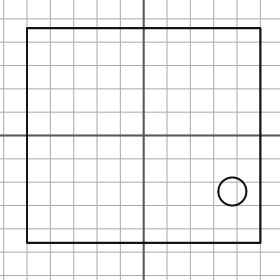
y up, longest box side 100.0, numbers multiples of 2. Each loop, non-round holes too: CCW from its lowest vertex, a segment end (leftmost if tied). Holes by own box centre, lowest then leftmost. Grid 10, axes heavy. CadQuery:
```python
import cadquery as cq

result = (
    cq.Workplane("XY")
    .moveTo(-50.0, -46.0)
    .lineTo(50.0, -46.0)
    .lineTo(50.0, 46.0)
    .lineTo(-50.0, 46.0)
    .close()
    .moveTo(38.0, -24.0)
    .circle(6.0)
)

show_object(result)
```